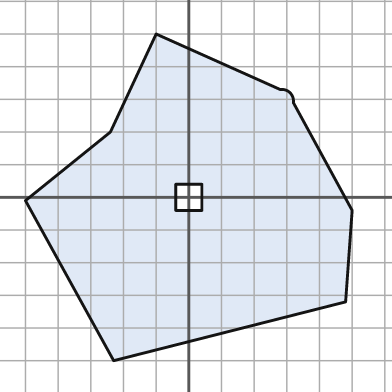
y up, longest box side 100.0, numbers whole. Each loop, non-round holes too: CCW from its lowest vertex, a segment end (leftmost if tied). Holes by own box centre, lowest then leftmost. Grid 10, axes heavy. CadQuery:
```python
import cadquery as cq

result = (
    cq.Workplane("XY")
    .moveTo(-23.0, -50.0)
    .lineTo(48.0, -32.0)
    .lineTo(50.0, -4.0)
    .lineTo(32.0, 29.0)
    .threePointArc((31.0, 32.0), (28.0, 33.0))
    .lineTo(-10.0, 50.0)
    .lineTo(-24.0, 20.0)
    .lineTo(-50.0, -1.0)
    .close()
    .moveTo(-4.0, -4.0)
    .lineTo(4.0, -4.0)
    .lineTo(4.0, 4.0)
    .lineTo(-4.0, 4.0)
    .close()
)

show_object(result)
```